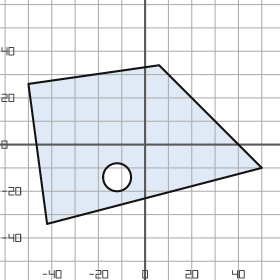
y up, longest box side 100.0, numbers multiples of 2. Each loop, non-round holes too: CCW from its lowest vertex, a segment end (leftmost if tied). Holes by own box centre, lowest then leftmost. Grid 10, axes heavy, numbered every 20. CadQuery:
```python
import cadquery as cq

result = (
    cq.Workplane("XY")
    .moveTo(-42.0, -34.0)
    .lineTo(50.0, -10.0)
    .lineTo(6.0, 34.0)
    .lineTo(-50.0, 26.0)
    .close()
    .moveTo(-12.0, -14.0)
    .circle(6.0)
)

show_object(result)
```